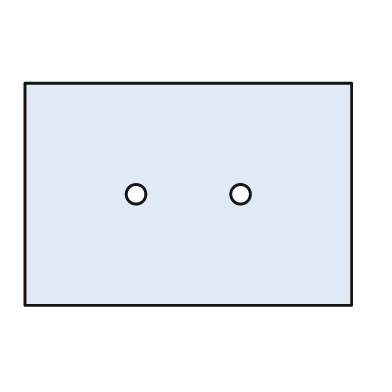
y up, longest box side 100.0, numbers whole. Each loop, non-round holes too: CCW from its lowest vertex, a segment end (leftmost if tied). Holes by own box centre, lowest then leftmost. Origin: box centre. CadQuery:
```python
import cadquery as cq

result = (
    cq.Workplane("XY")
    .moveTo(-50.0, -34.0)
    .lineTo(50.0, -34.0)
    .lineTo(50.0, 34.0)
    .lineTo(-50.0, 34.0)
    .close()
    .moveTo(-16.0, 0.0)
    .circle(3.0)
    .moveTo(16.0, 0.0)
    .circle(3.0)
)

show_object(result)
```